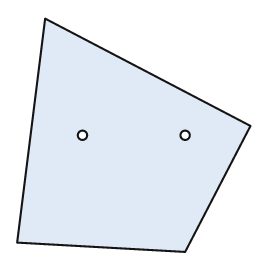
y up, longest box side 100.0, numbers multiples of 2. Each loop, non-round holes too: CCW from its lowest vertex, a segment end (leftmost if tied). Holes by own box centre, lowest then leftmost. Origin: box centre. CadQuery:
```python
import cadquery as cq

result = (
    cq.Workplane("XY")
    .moveTo(22.0, -50.0)
    .lineTo(50.0, 4.0)
    .lineTo(-38.0, 50.0)
    .lineTo(-50.0, -46.0)
    .close()
    .moveTo(-22.0, 0.0)
    .circle(2.0)
    .moveTo(22.0, 0.0)
    .circle(2.0)
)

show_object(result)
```